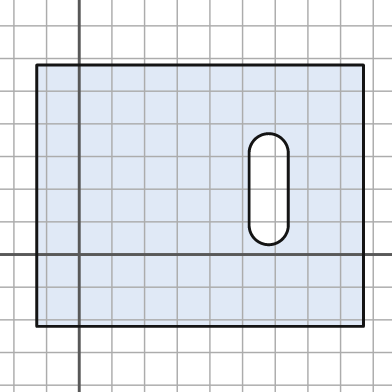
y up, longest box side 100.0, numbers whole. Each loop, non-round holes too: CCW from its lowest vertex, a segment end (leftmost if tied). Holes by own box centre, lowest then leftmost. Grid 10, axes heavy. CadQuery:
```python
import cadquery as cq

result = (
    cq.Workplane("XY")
    .moveTo(-13.0, -22.0)
    .lineTo(87.0, -22.0)
    .lineTo(87.0, 58.0)
    .lineTo(-13.0, 58.0)
    .close()
    .moveTo(52.0, 9.0)
    .threePointArc((58.0, 3.0), (64.0, 9.0))
    .lineTo(64.0, 31.0)
    .threePointArc((58.0, 37.0), (52.0, 31.0))
    .close()
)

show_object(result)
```